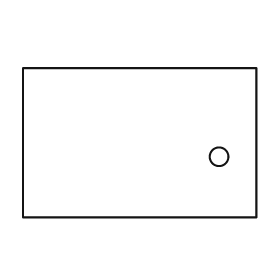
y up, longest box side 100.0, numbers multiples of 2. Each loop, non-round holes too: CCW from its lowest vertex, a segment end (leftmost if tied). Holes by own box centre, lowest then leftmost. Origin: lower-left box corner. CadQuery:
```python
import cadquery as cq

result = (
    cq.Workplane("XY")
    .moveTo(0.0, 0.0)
    .lineTo(100.0, 0.0)
    .lineTo(100.0, 64.0)
    .lineTo(0.0, 64.0)
    .close()
    .moveTo(84.0, 26.0)
    .circle(4.0)
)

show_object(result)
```